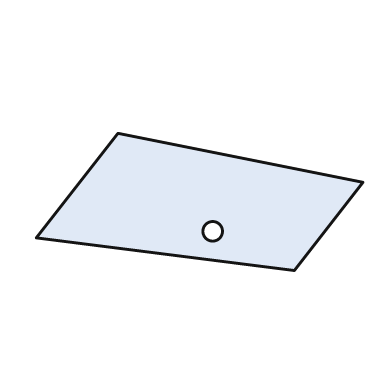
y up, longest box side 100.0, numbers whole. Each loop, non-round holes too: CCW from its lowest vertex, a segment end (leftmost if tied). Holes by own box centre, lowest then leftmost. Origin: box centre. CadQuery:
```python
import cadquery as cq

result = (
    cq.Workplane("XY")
    .moveTo(29.0, -21.0)
    .lineTo(50.0, 6.0)
    .lineTo(-25.0, 21.0)
    .lineTo(-50.0, -11.0)
    .close()
    .moveTo(4.0, -9.0)
    .circle(3.0)
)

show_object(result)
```